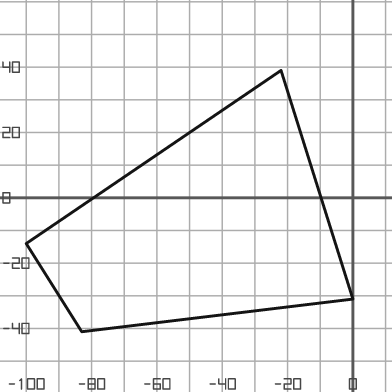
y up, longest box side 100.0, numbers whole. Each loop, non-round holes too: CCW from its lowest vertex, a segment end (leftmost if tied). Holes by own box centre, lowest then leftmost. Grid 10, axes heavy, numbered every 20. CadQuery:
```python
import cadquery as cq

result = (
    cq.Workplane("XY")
    .moveTo(-83.0, -41.0)
    .lineTo(0.0, -31.0)
    .lineTo(-22.0, 39.0)
    .lineTo(-100.0, -14.0)
    .close()
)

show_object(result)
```